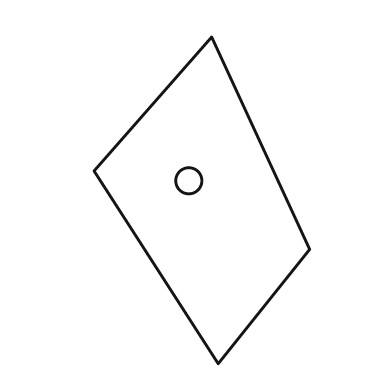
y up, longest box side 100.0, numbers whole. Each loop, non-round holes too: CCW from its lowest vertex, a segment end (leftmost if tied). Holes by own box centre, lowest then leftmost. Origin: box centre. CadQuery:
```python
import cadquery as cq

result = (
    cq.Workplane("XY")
    .moveTo(5.0, -50.0)
    .lineTo(33.0, -15.0)
    .lineTo(3.0, 50.0)
    .lineTo(-33.0, 9.0)
    .close()
    .moveTo(-4.0, 6.0)
    .circle(4.0)
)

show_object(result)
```